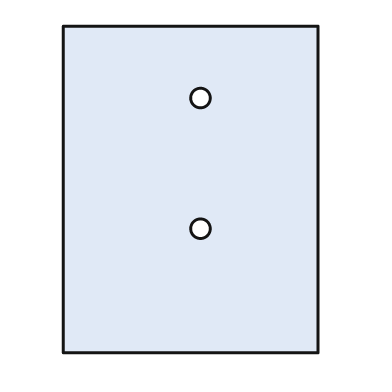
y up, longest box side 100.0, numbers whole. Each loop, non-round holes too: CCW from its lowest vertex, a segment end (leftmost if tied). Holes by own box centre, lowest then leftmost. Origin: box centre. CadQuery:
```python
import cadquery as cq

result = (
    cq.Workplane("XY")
    .moveTo(-39.0, -50.0)
    .lineTo(39.0, -50.0)
    .lineTo(39.0, 50.0)
    .lineTo(-39.0, 50.0)
    .close()
    .moveTo(3.0, -12.0)
    .circle(3.0)
    .moveTo(3.0, 28.0)
    .circle(3.0)
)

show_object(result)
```